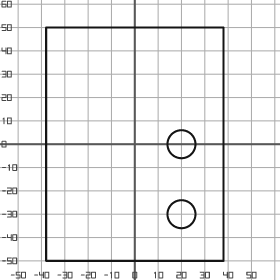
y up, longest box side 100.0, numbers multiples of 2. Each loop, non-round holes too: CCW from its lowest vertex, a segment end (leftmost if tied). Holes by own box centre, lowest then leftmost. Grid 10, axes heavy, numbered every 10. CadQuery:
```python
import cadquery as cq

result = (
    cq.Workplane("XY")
    .moveTo(-38.0, -50.0)
    .lineTo(38.0, -50.0)
    .lineTo(38.0, 50.0)
    .lineTo(-38.0, 50.0)
    .close()
    .moveTo(20.0, -30.0)
    .circle(6.0)
    .moveTo(20.0, 0.0)
    .circle(6.0)
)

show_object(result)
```